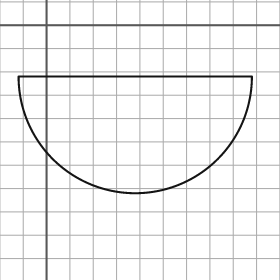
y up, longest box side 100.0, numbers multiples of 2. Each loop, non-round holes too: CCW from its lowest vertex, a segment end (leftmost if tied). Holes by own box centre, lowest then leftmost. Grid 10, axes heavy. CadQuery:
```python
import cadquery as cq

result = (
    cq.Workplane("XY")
    .moveTo(-12.0, -22.0)
    .threePointArc((38.0, -72.0), (88.0, -22.0))
    .close()
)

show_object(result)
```